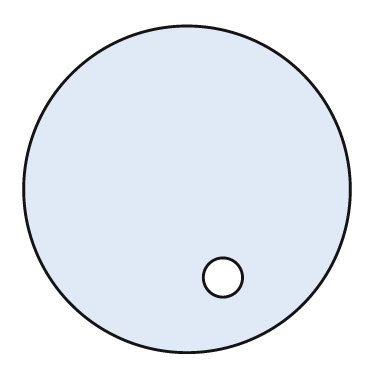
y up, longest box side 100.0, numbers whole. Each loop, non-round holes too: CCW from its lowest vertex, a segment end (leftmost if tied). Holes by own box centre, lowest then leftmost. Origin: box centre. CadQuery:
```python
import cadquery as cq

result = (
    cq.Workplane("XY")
    .moveTo(0.0, 0.0)
    .circle(50.0)
    .moveTo(11.0, -27.0)
    .circle(6.0)
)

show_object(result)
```